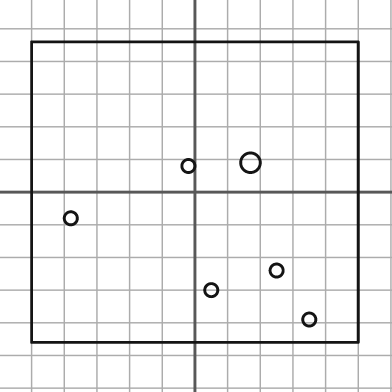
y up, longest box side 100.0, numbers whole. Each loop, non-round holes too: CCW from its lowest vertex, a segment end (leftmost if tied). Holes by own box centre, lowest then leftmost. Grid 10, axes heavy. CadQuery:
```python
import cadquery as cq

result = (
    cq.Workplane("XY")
    .moveTo(-50.0, -46.0)
    .lineTo(50.0, -46.0)
    .lineTo(50.0, 46.0)
    .lineTo(-50.0, 46.0)
    .close()
    .moveTo(35.0, -39.0)
    .circle(2.0)
    .moveTo(5.0, -30.0)
    .circle(2.0)
    .moveTo(25.0, -24.0)
    .circle(2.0)
    .moveTo(-38.0, -8.0)
    .circle(2.0)
    .moveTo(-2.0, 8.0)
    .circle(2.0)
    .moveTo(17.0, 9.0)
    .circle(3.0)
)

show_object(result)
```